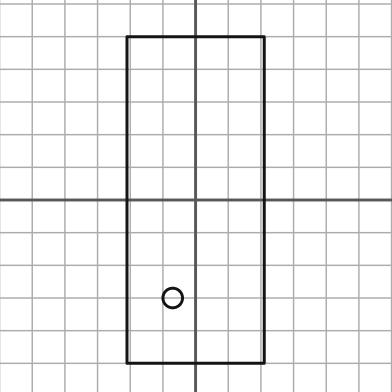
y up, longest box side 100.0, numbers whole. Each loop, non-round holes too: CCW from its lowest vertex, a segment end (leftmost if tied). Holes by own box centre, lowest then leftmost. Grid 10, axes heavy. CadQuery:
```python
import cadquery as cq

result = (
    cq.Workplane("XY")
    .moveTo(-21.0, -50.0)
    .lineTo(21.0, -50.0)
    .lineTo(21.0, 50.0)
    .lineTo(-21.0, 50.0)
    .close()
    .moveTo(-7.0, -30.0)
    .circle(3.0)
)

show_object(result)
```